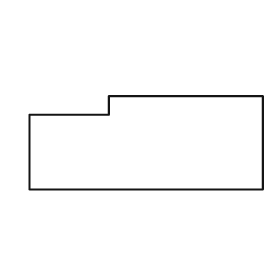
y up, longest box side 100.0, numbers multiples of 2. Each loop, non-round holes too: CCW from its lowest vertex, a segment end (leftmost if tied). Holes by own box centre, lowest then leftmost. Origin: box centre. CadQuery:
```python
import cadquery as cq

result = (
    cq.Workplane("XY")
    .moveTo(-50.0, -20.0)
    .lineTo(50.0, -20.0)
    .lineTo(50.0, 20.0)
    .lineTo(-16.0, 20.0)
    .lineTo(-16.0, 12.0)
    .lineTo(-50.0, 12.0)
    .close()
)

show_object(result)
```